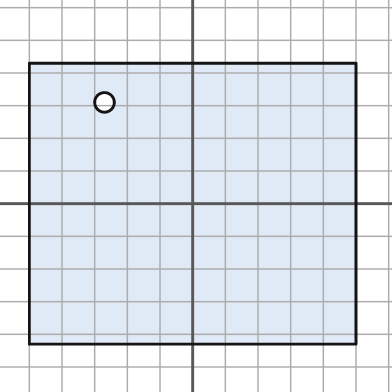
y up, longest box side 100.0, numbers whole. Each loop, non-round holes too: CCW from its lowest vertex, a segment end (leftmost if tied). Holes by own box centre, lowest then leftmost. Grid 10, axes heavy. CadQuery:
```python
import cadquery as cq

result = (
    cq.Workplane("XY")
    .moveTo(-50.0, -43.0)
    .lineTo(50.0, -43.0)
    .lineTo(50.0, 43.0)
    .lineTo(-50.0, 43.0)
    .close()
    .moveTo(-27.0, 31.0)
    .circle(3.0)
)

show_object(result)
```